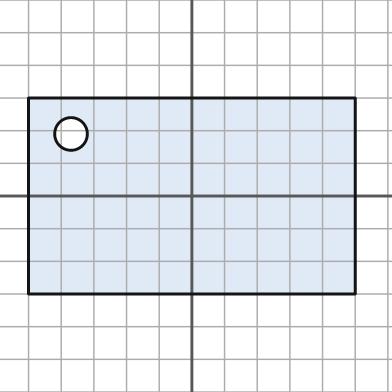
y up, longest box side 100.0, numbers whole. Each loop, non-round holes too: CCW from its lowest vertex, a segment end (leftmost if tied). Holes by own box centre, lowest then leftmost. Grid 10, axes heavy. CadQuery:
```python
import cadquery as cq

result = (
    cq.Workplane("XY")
    .moveTo(-50.0, -30.0)
    .lineTo(50.0, -30.0)
    .lineTo(50.0, 30.0)
    .lineTo(-50.0, 30.0)
    .close()
    .moveTo(-37.0, 19.0)
    .circle(5.0)
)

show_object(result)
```